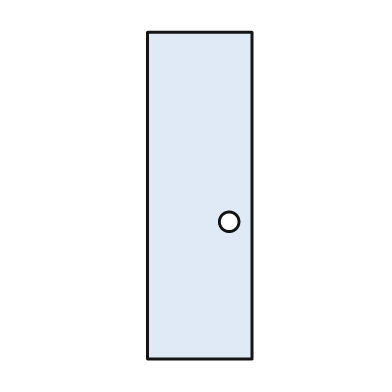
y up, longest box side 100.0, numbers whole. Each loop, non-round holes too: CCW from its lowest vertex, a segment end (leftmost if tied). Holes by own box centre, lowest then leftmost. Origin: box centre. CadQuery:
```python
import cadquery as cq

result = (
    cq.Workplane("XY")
    .moveTo(-16.0, -50.0)
    .lineTo(16.0, -50.0)
    .lineTo(16.0, 50.0)
    .lineTo(-16.0, 50.0)
    .close()
    .moveTo(9.0, -8.0)
    .circle(3.0)
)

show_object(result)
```